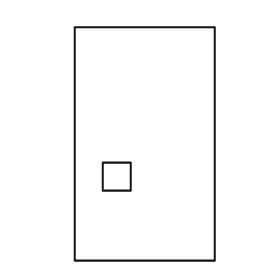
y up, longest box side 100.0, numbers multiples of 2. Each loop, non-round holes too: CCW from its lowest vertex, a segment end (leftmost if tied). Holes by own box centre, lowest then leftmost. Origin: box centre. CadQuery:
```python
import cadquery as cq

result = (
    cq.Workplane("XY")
    .moveTo(-30.0, -50.0)
    .lineTo(30.0, -50.0)
    .lineTo(30.0, 50.0)
    .lineTo(-30.0, 50.0)
    .close()
    .moveTo(-18.0, -20.0)
    .lineTo(-6.0, -20.0)
    .lineTo(-6.0, -8.0)
    .lineTo(-18.0, -8.0)
    .close()
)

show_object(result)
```